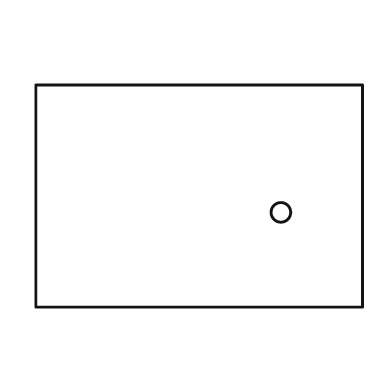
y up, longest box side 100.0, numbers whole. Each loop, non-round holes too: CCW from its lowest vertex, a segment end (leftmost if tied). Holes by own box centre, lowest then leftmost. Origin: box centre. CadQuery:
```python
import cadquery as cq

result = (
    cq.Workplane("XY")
    .moveTo(-50.0, -34.0)
    .lineTo(50.0, -34.0)
    .lineTo(50.0, 34.0)
    .lineTo(-50.0, 34.0)
    .close()
    .moveTo(25.0, -5.0)
    .circle(3.0)
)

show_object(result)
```